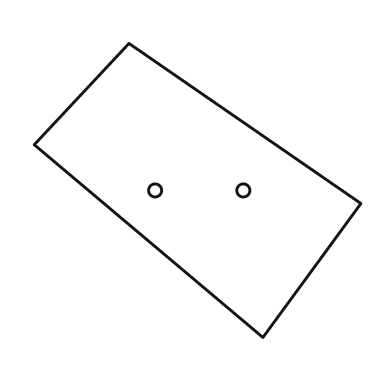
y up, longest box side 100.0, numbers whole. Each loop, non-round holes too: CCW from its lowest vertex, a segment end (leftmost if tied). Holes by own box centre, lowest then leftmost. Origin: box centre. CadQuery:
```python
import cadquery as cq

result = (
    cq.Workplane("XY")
    .moveTo(20.0, -45.0)
    .lineTo(50.0, -4.0)
    .lineTo(-21.0, 45.0)
    .lineTo(-50.0, 14.0)
    .close()
    .moveTo(-13.0, 0.0)
    .circle(2.0)
    .moveTo(14.0, 0.0)
    .circle(2.0)
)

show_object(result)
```